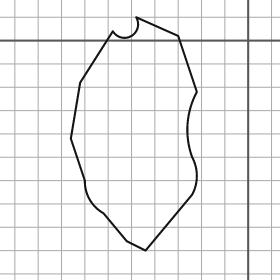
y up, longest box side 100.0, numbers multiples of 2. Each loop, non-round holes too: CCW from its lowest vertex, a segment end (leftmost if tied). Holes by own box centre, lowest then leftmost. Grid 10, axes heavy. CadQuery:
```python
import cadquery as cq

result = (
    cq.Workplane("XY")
    .moveTo(-44.0, -90.0)
    .lineTo(-24.0, -66.0)
    .threePointArc((-22.0, -58.0), (-24.0, -50.0))
    .threePointArc((-26.0, -36.0), (-22.0, -22.0))
    .lineTo(-30.0, 2.0)
    .lineTo(-48.0, 10.0)
    .threePointArc((-50.0, 2.0), (-58.0, 4.0))
    .lineTo(-72.0, -18.0)
    .lineTo(-76.0, -42.0)
    .lineTo(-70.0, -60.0)
    .threePointArc((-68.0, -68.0), (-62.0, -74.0))
    .lineTo(-52.0, -86.0)
    .close()
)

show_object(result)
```